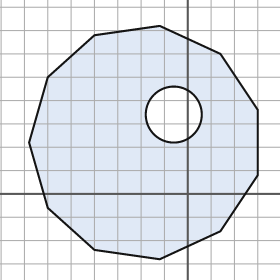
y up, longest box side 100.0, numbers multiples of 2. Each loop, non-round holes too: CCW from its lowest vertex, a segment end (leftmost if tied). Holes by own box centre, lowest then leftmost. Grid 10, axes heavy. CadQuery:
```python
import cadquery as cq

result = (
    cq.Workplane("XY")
    .moveTo(-12.0, -28.0)
    .lineTo(14.0, -16.0)
    .lineTo(30.0, 8.0)
    .lineTo(30.0, 36.0)
    .lineTo(14.0, 60.0)
    .lineTo(-12.0, 72.0)
    .lineTo(-40.0, 68.0)
    .lineTo(-60.0, 50.0)
    .lineTo(-68.0, 22.0)
    .lineTo(-60.0, -6.0)
    .lineTo(-40.0, -24.0)
    .close()
    .moveTo(-6.0, 34.0)
    .circle(12.0)
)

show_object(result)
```